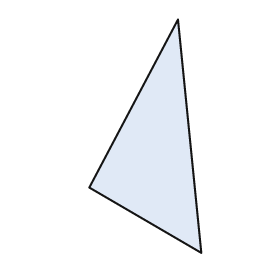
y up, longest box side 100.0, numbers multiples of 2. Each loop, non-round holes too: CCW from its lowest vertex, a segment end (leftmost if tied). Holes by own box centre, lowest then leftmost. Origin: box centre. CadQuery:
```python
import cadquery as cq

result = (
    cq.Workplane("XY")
    .moveTo(24.0, -50.0)
    .lineTo(14.0, 50.0)
    .lineTo(-24.0, -22.0)
    .close()
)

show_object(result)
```